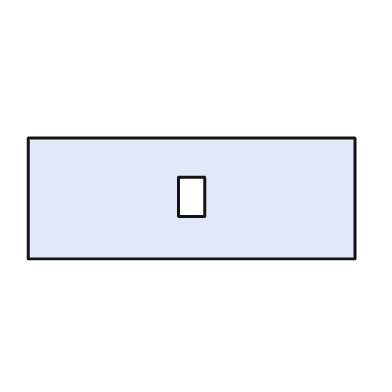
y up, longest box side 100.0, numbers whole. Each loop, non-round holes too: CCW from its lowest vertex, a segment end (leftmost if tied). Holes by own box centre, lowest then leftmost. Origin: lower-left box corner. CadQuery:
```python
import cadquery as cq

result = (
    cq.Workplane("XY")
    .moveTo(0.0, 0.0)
    .lineTo(100.0, 0.0)
    .lineTo(100.0, 37.0)
    .lineTo(0.0, 37.0)
    .close()
    .moveTo(46.0, 13.0)
    .lineTo(54.0, 13.0)
    .lineTo(54.0, 25.0)
    .lineTo(46.0, 25.0)
    .close()
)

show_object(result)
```